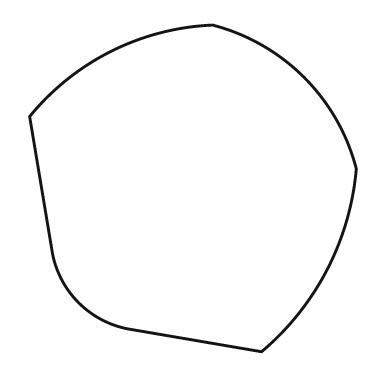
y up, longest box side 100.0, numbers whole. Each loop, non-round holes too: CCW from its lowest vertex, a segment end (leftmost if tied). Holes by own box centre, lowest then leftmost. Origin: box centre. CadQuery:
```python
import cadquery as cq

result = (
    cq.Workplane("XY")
    .moveTo(21.0, -50.0)
    .threePointArc((41.0, -25.0), (50.0, 6.0))
    .threePointArc((34.0, 34.0), (6.0, 50.0))
    .threePointArc((-25.0, 42.0), (-50.0, 22.0))
    .lineTo(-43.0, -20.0)
    .threePointArc((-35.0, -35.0), (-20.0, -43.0))
    .close()
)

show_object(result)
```